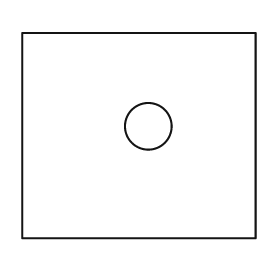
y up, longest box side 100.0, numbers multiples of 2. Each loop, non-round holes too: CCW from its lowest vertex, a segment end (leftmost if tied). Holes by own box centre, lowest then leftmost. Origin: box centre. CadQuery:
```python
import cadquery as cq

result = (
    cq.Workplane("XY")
    .moveTo(-50.0, -44.0)
    .lineTo(50.0, -44.0)
    .lineTo(50.0, 44.0)
    .lineTo(-50.0, 44.0)
    .close()
    .moveTo(4.0, 4.0)
    .circle(10.0)
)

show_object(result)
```